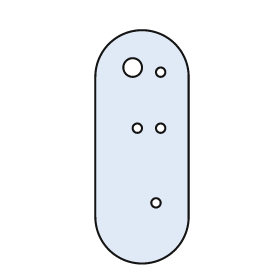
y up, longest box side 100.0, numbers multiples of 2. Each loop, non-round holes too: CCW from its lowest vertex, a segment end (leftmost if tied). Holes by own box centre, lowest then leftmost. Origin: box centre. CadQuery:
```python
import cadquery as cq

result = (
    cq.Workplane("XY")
    .moveTo(-20.0, -30.0)
    .threePointArc((0.0, -50.0), (20.0, -30.0))
    .lineTo(20.0, 30.0)
    .threePointArc((0.0, 50.0), (-20.0, 30.0))
    .close()
    .moveTo(6.0, -24.0)
    .circle(2.0)
    .moveTo(-2.0, 8.0)
    .circle(2.0)
    .moveTo(8.0, 8.0)
    .circle(2.0)
    .moveTo(8.0, 32.0)
    .circle(2.0)
    .moveTo(-4.0, 34.0)
    .circle(4.0)
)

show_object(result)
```